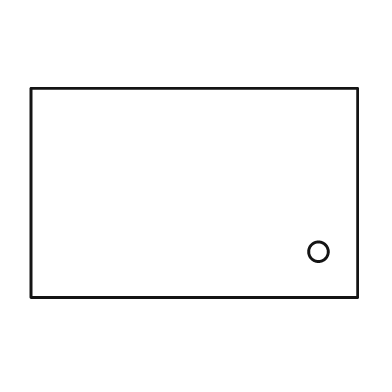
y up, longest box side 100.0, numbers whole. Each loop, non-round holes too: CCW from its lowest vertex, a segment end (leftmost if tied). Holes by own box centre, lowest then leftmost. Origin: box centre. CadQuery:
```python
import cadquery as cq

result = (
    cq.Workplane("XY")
    .moveTo(-50.0, -32.0)
    .lineTo(50.0, -32.0)
    .lineTo(50.0, 32.0)
    .lineTo(-50.0, 32.0)
    .close()
    .moveTo(38.0, -18.0)
    .circle(3.0)
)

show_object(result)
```